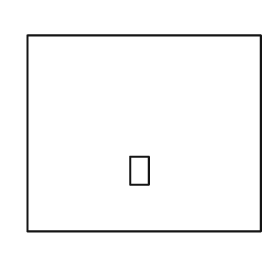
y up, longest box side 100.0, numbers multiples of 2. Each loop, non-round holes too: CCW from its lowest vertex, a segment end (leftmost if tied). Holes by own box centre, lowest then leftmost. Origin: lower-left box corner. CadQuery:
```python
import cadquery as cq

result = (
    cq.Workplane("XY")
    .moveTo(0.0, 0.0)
    .lineTo(100.0, 0.0)
    .lineTo(100.0, 84.0)
    .lineTo(0.0, 84.0)
    .close()
    .moveTo(44.0, 20.0)
    .lineTo(52.0, 20.0)
    .lineTo(52.0, 32.0)
    .lineTo(44.0, 32.0)
    .close()
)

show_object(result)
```